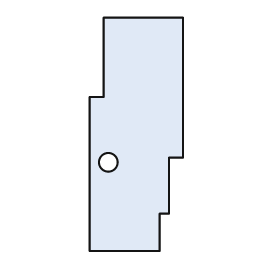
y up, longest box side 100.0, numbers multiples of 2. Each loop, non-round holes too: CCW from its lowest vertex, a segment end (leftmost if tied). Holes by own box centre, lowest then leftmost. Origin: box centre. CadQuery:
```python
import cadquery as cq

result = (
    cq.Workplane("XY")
    .moveTo(-20.0, -50.0)
    .lineTo(10.0, -50.0)
    .lineTo(10.0, -34.0)
    .lineTo(14.0, -34.0)
    .lineTo(14.0, -10.0)
    .lineTo(20.0, -10.0)
    .lineTo(20.0, 50.0)
    .lineTo(-14.0, 50.0)
    .lineTo(-14.0, 16.0)
    .lineTo(-20.0, 16.0)
    .close()
    .moveTo(-12.0, -12.0)
    .circle(4.0)
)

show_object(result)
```